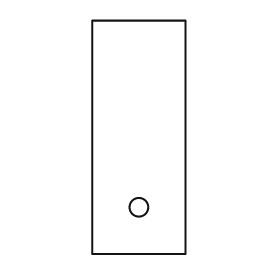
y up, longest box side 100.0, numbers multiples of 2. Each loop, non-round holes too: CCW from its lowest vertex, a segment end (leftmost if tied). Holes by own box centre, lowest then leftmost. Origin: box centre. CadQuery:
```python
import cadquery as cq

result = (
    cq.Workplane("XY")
    .moveTo(-20.0, -50.0)
    .lineTo(20.0, -50.0)
    .lineTo(20.0, 50.0)
    .lineTo(-20.0, 50.0)
    .close()
    .moveTo(0.0, -30.0)
    .circle(4.0)
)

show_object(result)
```